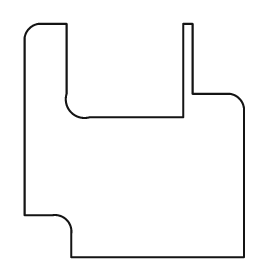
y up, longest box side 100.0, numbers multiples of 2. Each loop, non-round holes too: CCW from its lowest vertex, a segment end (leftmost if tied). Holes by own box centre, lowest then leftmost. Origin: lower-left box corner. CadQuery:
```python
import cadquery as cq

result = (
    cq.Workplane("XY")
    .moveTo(20.0, 0.0)
    .lineTo(94.0, 0.0)
    .lineTo(94.0, 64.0)
    .threePointArc((92.0, 68.0), (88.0, 70.0))
    .lineTo(72.0, 70.0)
    .lineTo(72.0, 100.0)
    .lineTo(68.0, 100.0)
    .lineTo(68.0, 60.0)
    .lineTo(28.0, 60.0)
    .threePointArc((20.0, 62.0), (18.0, 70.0))
    .lineTo(18.0, 100.0)
    .lineTo(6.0, 100.0)
    .threePointArc((2.0, 98.0), (0.0, 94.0))
    .lineTo(0.0, 18.0)
    .lineTo(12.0, 18.0)
    .threePointArc((18.0, 16.0), (20.0, 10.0))
    .close()
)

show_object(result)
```